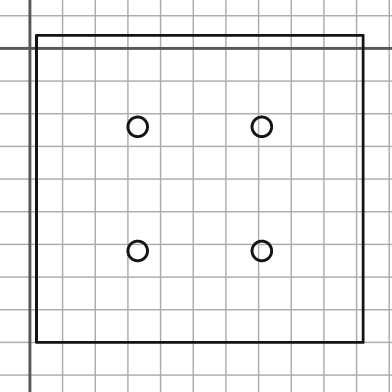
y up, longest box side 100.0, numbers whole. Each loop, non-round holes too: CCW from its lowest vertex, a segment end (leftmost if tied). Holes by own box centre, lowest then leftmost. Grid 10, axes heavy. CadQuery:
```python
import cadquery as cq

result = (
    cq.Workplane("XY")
    .moveTo(2.0, -90.0)
    .lineTo(102.0, -90.0)
    .lineTo(102.0, 4.0)
    .lineTo(2.0, 4.0)
    .close()
    .moveTo(33.0, -62.0)
    .circle(3.0)
    .moveTo(71.0, -62.0)
    .circle(3.0)
    .moveTo(33.0, -24.0)
    .circle(3.0)
    .moveTo(71.0, -24.0)
    .circle(3.0)
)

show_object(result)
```